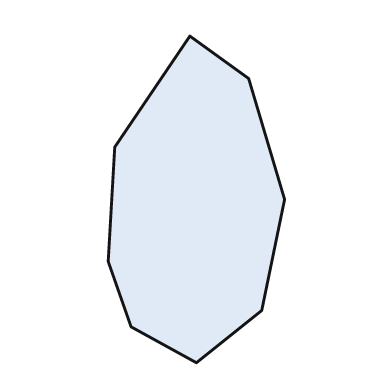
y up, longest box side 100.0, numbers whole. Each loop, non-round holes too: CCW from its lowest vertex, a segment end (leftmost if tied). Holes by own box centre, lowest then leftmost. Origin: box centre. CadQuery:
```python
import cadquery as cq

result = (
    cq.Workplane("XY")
    .moveTo(0.0, -50.0)
    .lineTo(20.0, -34.0)
    .lineTo(27.0, 0.0)
    .lineTo(16.0, 37.0)
    .lineTo(-2.0, 50.0)
    .lineTo(-25.0, 16.0)
    .lineTo(-27.0, -19.0)
    .lineTo(-20.0, -39.0)
    .close()
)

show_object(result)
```